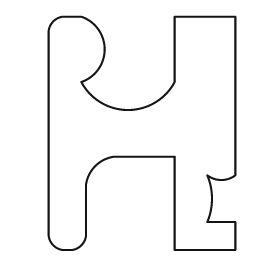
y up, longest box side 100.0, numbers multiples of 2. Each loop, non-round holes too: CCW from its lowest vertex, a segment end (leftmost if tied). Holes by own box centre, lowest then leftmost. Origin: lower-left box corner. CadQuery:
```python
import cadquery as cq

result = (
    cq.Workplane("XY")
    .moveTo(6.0, 0.0)
    .lineTo(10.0, 0.0)
    .threePointArc((14.0, 2.0), (16.0, 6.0))
    .lineTo(16.0, 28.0)
    .threePointArc((20.0, 36.0), (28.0, 40.0))
    .lineTo(54.0, 40.0)
    .lineTo(54.0, 0.0)
    .lineTo(80.0, 0.0)
    .lineTo(80.0, 12.0)
    .lineTo(68.0, 12.0)
    .threePointArc((70.0, 22.0), (68.0, 32.0))
    .threePointArc((74.0, 30.0), (80.0, 32.0))
    .lineTo(80.0, 100.0)
    .lineTo(54.0, 100.0)
    .lineTo(54.0, 72.0)
    .threePointArc((34.0, 60.0), (14.0, 72.0))
    .threePointArc((24.0, 86.0), (14.0, 100.0))
    .lineTo(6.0, 100.0)
    .threePointArc((2.0, 98.0), (0.0, 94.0))
    .lineTo(0.0, 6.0)
    .threePointArc((2.0, 2.0), (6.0, 0.0))
    .close()
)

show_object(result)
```